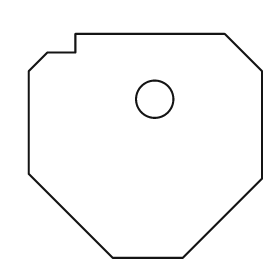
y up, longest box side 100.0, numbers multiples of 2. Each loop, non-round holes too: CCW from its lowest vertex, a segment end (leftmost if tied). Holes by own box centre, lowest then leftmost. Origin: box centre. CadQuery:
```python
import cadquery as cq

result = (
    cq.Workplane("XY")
    .moveTo(-14.0, -48.0)
    .lineTo(16.0, -48.0)
    .lineTo(50.0, -14.0)
    .lineTo(50.0, 32.0)
    .lineTo(34.0, 48.0)
    .lineTo(-30.0, 48.0)
    .lineTo(-30.0, 40.0)
    .lineTo(-42.0, 40.0)
    .lineTo(-50.0, 32.0)
    .lineTo(-50.0, -12.0)
    .close()
    .moveTo(4.0, 20.0)
    .circle(8.0)
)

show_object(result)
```